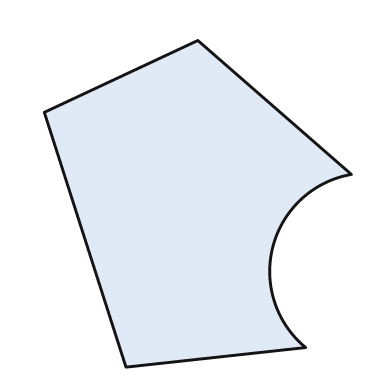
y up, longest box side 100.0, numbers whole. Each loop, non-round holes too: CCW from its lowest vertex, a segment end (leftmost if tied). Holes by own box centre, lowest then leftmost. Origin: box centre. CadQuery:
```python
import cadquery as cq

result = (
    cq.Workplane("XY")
    .moveTo(-22.0, -50.0)
    .lineTo(33.0, -44.0)
    .threePointArc((23.0, -13.0), (47.0, 9.0))
    .lineTo(0.0, 50.0)
    .lineTo(-47.0, 28.0)
    .close()
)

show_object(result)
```